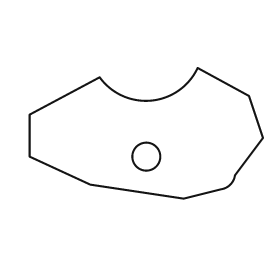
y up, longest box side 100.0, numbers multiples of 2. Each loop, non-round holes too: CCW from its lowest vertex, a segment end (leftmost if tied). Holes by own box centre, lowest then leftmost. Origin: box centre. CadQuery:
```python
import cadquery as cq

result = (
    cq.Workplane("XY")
    .moveTo(16.0, -28.0)
    .lineTo(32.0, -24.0)
    .threePointArc((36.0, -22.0), (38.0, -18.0))
    .lineTo(50.0, -2.0)
    .lineTo(44.0, 16.0)
    .lineTo(22.0, 28.0)
    .threePointArc((2.0, 14.0), (-20.0, 24.0))
    .lineTo(-50.0, 8.0)
    .lineTo(-50.0, -10.0)
    .lineTo(-24.0, -22.0)
    .close()
    .moveTo(0.0, -10.0)
    .circle(6.0)
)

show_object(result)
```